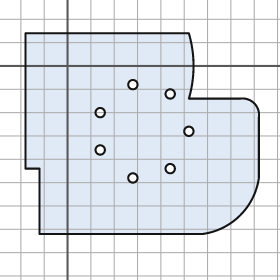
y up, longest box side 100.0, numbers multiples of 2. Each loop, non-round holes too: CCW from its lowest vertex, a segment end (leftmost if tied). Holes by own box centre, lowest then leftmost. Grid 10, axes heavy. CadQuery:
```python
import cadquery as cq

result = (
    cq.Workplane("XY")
    .moveTo(-12.0, -72.0)
    .lineTo(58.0, -72.0)
    .threePointArc((74.0, -64.0), (82.0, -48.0))
    .lineTo(82.0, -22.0)
    .threePointArc((80.0, -16.0), (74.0, -14.0))
    .lineTo(52.0, -14.0)
    .threePointArc((54.0, 0.0), (52.0, 14.0))
    .lineTo(-18.0, 14.0)
    .lineTo(-18.0, -44.0)
    .lineTo(-12.0, -44.0)
    .close()
    .moveTo(28.0, -48.0)
    .circle(2.0)
    .moveTo(44.0, -44.0)
    .circle(2.0)
    .moveTo(14.0, -36.0)
    .circle(2.0)
    .moveTo(52.0, -28.0)
    .circle(2.0)
    .moveTo(14.0, -20.0)
    .circle(2.0)
    .moveTo(44.0, -12.0)
    .circle(2.0)
    .moveTo(28.0, -8.0)
    .circle(2.0)
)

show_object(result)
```